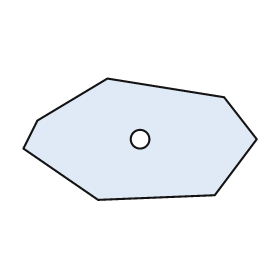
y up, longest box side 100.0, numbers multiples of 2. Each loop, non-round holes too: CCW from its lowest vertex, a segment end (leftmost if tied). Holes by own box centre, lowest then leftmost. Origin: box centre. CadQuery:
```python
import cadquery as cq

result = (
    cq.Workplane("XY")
    .moveTo(-18.0, -26.0)
    .lineTo(32.0, -24.0)
    .lineTo(50.0, 0.0)
    .lineTo(36.0, 18.0)
    .lineTo(-14.0, 26.0)
    .lineTo(-44.0, 8.0)
    .lineTo(-50.0, -4.0)
    .close()
    .moveTo(0.0, 0.0)
    .circle(4.0)
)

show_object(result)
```